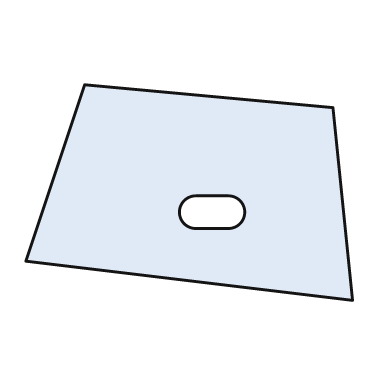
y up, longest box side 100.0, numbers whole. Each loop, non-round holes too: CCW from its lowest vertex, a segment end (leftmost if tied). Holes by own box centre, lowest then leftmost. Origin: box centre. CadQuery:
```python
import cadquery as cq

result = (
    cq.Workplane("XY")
    .moveTo(50.0, -33.0)
    .lineTo(44.0, 26.0)
    .lineTo(-32.0, 33.0)
    .lineTo(-50.0, -21.0)
    .close()
    .moveTo(2.0, -11.0)
    .lineTo(12.0, -11.0)
    .threePointArc((17.0, -6.0), (12.0, -1.0))
    .lineTo(2.0, -1.0)
    .threePointArc((-3.0, -6.0), (2.0, -11.0))
    .close()
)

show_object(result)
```